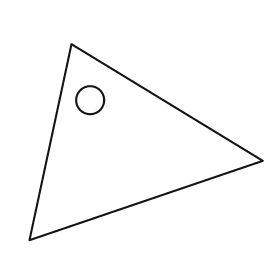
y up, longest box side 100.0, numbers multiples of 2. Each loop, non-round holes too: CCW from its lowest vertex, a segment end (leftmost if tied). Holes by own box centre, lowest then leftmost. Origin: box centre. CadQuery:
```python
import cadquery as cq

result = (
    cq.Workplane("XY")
    .moveTo(-50.0, -42.0)
    .lineTo(50.0, -8.0)
    .lineTo(-32.0, 42.0)
    .close()
    .moveTo(-24.0, 18.0)
    .circle(6.0)
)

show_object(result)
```